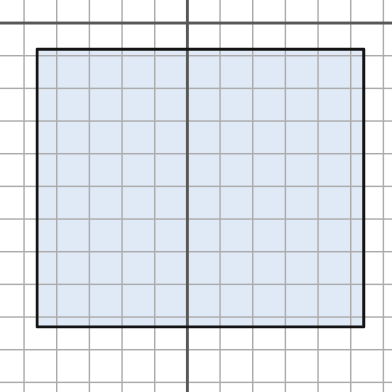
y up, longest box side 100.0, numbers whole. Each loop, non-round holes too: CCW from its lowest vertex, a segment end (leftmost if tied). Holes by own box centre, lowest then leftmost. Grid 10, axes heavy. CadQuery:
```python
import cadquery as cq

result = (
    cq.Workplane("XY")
    .moveTo(-46.0, -93.0)
    .lineTo(54.0, -93.0)
    .lineTo(54.0, -8.0)
    .lineTo(-46.0, -8.0)
    .close()
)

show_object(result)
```